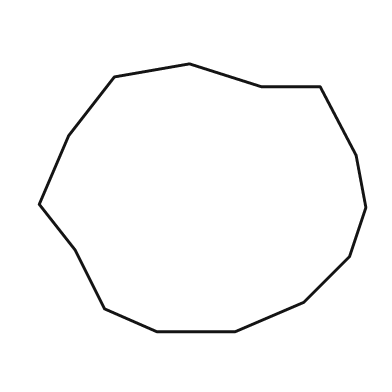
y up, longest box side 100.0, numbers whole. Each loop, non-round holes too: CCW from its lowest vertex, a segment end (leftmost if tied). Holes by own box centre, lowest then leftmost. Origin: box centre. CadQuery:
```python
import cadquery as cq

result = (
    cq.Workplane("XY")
    .moveTo(-14.0, -41.0)
    .lineTo(10.0, -41.0)
    .lineTo(31.0, -32.0)
    .lineTo(45.0, -18.0)
    .lineTo(50.0, -3.0)
    .lineTo(47.0, 13.0)
    .lineTo(36.0, 34.0)
    .lineTo(18.0, 34.0)
    .lineTo(-4.0, 41.0)
    .lineTo(-27.0, 37.0)
    .lineTo(-41.0, 19.0)
    .lineTo(-50.0, -2.0)
    .lineTo(-39.0, -16.0)
    .lineTo(-30.0, -34.0)
    .close()
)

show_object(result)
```